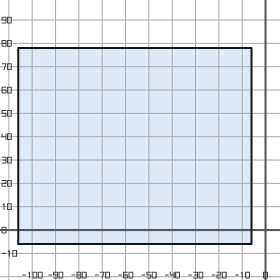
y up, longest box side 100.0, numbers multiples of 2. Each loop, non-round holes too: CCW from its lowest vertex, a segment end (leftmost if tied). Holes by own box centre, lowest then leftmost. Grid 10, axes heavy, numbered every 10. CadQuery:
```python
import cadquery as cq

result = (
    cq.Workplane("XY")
    .moveTo(-106.0, -6.0)
    .lineTo(-6.0, -6.0)
    .lineTo(-6.0, 78.0)
    .lineTo(-106.0, 78.0)
    .close()
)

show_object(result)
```